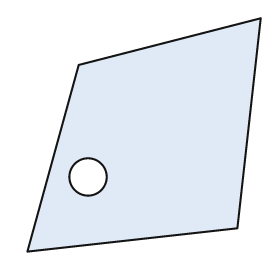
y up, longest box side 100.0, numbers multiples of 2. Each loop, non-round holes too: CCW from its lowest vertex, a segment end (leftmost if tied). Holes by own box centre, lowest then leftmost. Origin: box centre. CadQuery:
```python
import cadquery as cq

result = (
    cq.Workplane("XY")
    .moveTo(-50.0, -50.0)
    .lineTo(40.0, -40.0)
    .lineTo(50.0, 50.0)
    .lineTo(-28.0, 30.0)
    .close()
    .moveTo(-24.0, -18.0)
    .circle(8.0)
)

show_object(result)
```